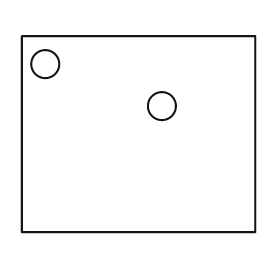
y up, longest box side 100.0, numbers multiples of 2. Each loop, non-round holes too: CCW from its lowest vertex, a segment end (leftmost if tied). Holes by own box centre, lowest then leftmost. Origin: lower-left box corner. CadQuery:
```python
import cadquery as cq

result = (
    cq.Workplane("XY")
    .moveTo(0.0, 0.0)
    .lineTo(100.0, 0.0)
    .lineTo(100.0, 84.0)
    .lineTo(0.0, 84.0)
    .close()
    .moveTo(60.0, 54.0)
    .circle(6.0)
    .moveTo(10.0, 72.0)
    .circle(6.0)
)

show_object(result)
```